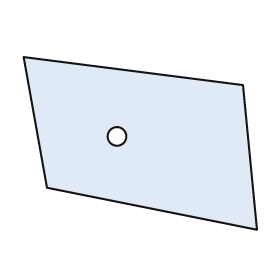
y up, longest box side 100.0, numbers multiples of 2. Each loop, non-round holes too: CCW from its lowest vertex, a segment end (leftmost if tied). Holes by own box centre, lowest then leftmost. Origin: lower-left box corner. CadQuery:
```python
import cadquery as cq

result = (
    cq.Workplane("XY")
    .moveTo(100.0, 0.0)
    .lineTo(94.0, 62.0)
    .lineTo(0.0, 74.0)
    .lineTo(10.0, 18.0)
    .close()
    .moveTo(40.0, 40.0)
    .circle(4.0)
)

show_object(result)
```